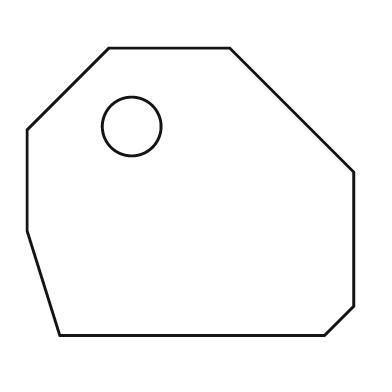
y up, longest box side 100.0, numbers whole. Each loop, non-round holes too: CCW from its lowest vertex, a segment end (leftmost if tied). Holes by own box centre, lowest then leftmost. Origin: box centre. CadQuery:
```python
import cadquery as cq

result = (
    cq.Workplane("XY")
    .moveTo(-40.0, -44.0)
    .lineTo(41.0, -44.0)
    .lineTo(50.0, -35.0)
    .lineTo(50.0, 6.0)
    .lineTo(12.0, 44.0)
    .lineTo(-25.0, 44.0)
    .lineTo(-50.0, 19.0)
    .lineTo(-50.0, -12.0)
    .close()
    .moveTo(-18.0, 20.0)
    .circle(9.0)
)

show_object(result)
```